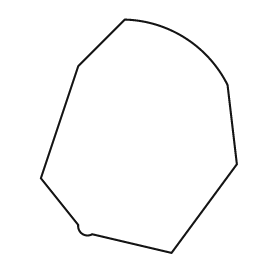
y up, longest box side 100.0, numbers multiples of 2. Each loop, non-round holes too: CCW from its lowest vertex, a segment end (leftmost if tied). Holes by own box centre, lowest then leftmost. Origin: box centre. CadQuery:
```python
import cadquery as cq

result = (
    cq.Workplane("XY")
    .moveTo(14.0, -50.0)
    .lineTo(42.0, -12.0)
    .lineTo(38.0, 22.0)
    .threePointArc((20.0, 42.0), (-6.0, 50.0))
    .lineTo(-26.0, 30.0)
    .lineTo(-42.0, -18.0)
    .lineTo(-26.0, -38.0)
    .threePointArc((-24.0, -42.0), (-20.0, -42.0))
    .close()
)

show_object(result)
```